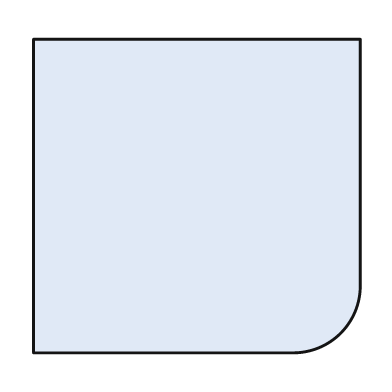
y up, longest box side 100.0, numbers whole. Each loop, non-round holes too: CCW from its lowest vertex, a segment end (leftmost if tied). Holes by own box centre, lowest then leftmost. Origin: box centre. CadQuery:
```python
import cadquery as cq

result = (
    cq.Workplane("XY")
    .moveTo(-50.0, -48.0)
    .lineTo(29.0, -48.0)
    .threePointArc((44.0, -42.0), (50.0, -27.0))
    .lineTo(50.0, 48.0)
    .lineTo(-50.0, 48.0)
    .close()
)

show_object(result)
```